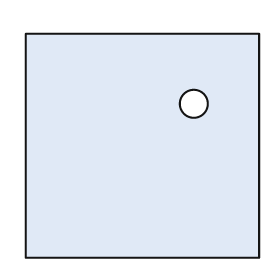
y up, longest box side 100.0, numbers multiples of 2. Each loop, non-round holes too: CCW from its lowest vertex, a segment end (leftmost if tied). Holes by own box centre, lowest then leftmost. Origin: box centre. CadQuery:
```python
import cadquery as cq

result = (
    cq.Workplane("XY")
    .moveTo(-50.0, -48.0)
    .lineTo(50.0, -48.0)
    .lineTo(50.0, 48.0)
    .lineTo(-50.0, 48.0)
    .close()
    .moveTo(22.0, 18.0)
    .circle(6.0)
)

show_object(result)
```